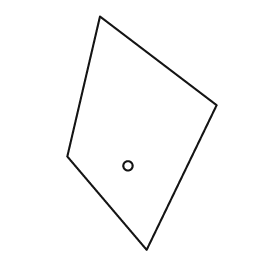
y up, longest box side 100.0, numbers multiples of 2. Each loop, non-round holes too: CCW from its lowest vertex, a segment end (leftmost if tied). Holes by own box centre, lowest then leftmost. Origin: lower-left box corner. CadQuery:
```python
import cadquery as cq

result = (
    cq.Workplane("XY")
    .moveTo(34.0, 0.0)
    .lineTo(64.0, 62.0)
    .lineTo(14.0, 100.0)
    .lineTo(0.0, 40.0)
    .close()
    .moveTo(26.0, 36.0)
    .circle(2.0)
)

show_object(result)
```